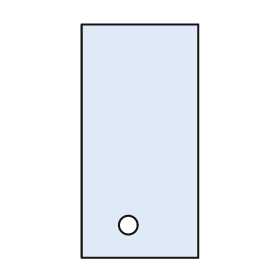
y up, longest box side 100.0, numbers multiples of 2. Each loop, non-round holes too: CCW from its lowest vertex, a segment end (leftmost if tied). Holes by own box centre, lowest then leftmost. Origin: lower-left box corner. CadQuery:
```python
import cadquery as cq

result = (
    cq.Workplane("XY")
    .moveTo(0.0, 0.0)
    .lineTo(50.0, 0.0)
    .lineTo(50.0, 100.0)
    .lineTo(0.0, 100.0)
    .close()
    .moveTo(20.0, 14.0)
    .circle(4.0)
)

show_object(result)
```